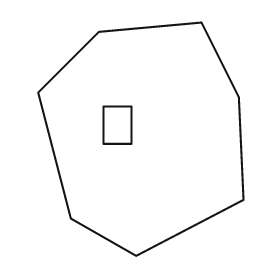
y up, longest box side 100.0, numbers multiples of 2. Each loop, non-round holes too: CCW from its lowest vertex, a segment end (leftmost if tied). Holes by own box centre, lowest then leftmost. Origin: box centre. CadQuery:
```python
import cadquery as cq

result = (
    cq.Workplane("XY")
    .moveTo(-2.0, -50.0)
    .lineTo(44.0, -26.0)
    .lineTo(42.0, 18.0)
    .lineTo(26.0, 50.0)
    .lineTo(-18.0, 46.0)
    .lineTo(-44.0, 20.0)
    .lineTo(-30.0, -34.0)
    .close()
    .moveTo(-16.0, -2.0)
    .lineTo(-4.0, -2.0)
    .lineTo(-4.0, 14.0)
    .lineTo(-16.0, 14.0)
    .close()
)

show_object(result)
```